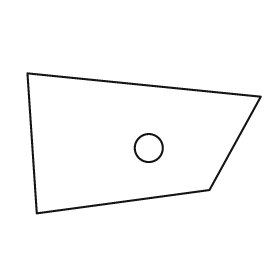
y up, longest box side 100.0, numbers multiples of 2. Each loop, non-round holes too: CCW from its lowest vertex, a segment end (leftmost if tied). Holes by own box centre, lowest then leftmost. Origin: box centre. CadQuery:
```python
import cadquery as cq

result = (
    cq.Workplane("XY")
    .moveTo(-46.0, -30.0)
    .lineTo(28.0, -20.0)
    .lineTo(50.0, 20.0)
    .lineTo(-50.0, 30.0)
    .close()
    .moveTo(2.0, -2.0)
    .circle(6.0)
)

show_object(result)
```